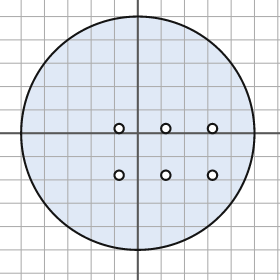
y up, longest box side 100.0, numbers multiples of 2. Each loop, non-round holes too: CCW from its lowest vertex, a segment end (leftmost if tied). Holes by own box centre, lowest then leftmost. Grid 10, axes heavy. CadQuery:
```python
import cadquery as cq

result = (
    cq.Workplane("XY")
    .moveTo(0.0, 0.0)
    .circle(50.0)
    .moveTo(-8.0, -18.0)
    .circle(2.0)
    .moveTo(12.0, -18.0)
    .circle(2.0)
    .moveTo(32.0, -18.0)
    .circle(2.0)
    .moveTo(-8.0, 2.0)
    .circle(2.0)
    .moveTo(12.0, 2.0)
    .circle(2.0)
    .moveTo(32.0, 2.0)
    .circle(2.0)
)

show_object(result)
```